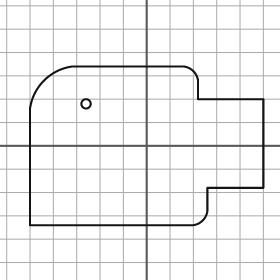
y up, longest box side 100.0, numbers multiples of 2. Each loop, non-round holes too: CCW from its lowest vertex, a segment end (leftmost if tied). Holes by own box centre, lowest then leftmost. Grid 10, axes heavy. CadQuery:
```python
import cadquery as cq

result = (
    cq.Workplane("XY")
    .moveTo(-50.0, -34.0)
    .lineTo(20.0, -34.0)
    .threePointArc((24.0, -32.0), (26.0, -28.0))
    .lineTo(26.0, -18.0)
    .lineTo(50.0, -18.0)
    .lineTo(50.0, 20.0)
    .lineTo(22.0, 20.0)
    .lineTo(22.0, 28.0)
    .threePointArc((20.0, 32.0), (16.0, 34.0))
    .lineTo(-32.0, 34.0)
    .threePointArc((-44.0, 28.0), (-50.0, 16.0))
    .close()
    .moveTo(-26.0, 18.0)
    .circle(2.0)
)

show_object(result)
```